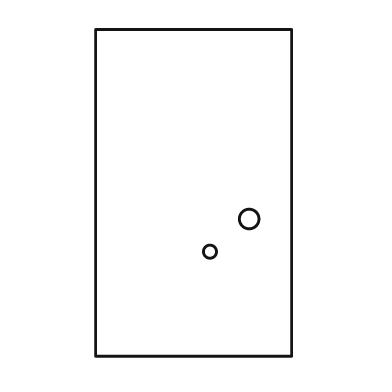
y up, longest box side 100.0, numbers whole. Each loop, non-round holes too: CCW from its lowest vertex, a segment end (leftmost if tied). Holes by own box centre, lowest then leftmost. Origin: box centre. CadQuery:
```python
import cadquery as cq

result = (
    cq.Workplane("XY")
    .moveTo(-30.0, -50.0)
    .lineTo(30.0, -50.0)
    .lineTo(30.0, 50.0)
    .lineTo(-30.0, 50.0)
    .close()
    .moveTo(5.0, -18.0)
    .circle(2.0)
    .moveTo(17.0, -8.0)
    .circle(3.0)
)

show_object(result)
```